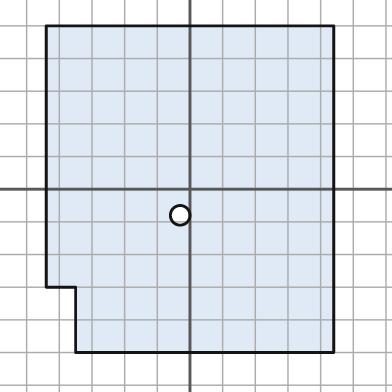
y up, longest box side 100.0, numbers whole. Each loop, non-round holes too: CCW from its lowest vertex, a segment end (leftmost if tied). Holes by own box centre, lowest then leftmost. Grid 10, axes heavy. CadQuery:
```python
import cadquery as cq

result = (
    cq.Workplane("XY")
    .moveTo(-35.0, -50.0)
    .lineTo(44.0, -50.0)
    .lineTo(44.0, 50.0)
    .lineTo(-44.0, 50.0)
    .lineTo(-44.0, -30.0)
    .lineTo(-35.0, -30.0)
    .close()
    .moveTo(-3.0, -8.0)
    .circle(3.0)
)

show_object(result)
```